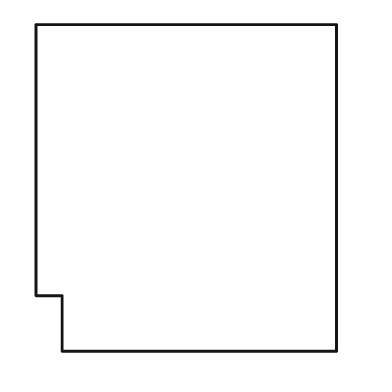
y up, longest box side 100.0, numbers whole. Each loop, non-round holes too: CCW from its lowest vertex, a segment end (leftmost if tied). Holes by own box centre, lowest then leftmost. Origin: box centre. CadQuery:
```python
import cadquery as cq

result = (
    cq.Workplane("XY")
    .moveTo(-38.0, -50.0)
    .lineTo(46.0, -50.0)
    .lineTo(46.0, 50.0)
    .lineTo(-46.0, 50.0)
    .lineTo(-46.0, -33.0)
    .lineTo(-38.0, -33.0)
    .close()
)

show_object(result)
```